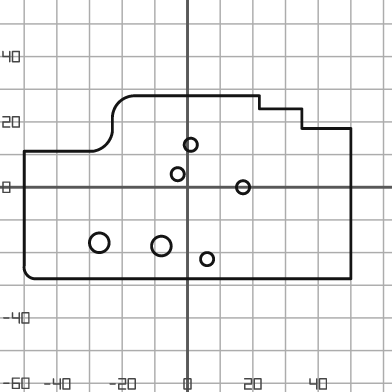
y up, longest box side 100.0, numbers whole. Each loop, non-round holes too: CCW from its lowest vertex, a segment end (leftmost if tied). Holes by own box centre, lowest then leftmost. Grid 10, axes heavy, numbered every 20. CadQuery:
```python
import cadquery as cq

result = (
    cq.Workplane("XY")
    .moveTo(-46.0, -28.0)
    .lineTo(50.0, -28.0)
    .lineTo(50.0, 18.0)
    .lineTo(35.0, 18.0)
    .lineTo(35.0, 24.0)
    .lineTo(22.0, 24.0)
    .lineTo(22.0, 28.0)
    .lineTo(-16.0, 28.0)
    .threePointArc((-21.0, 26.0), (-23.0, 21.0))
    .lineTo(-23.0, 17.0)
    .threePointArc((-25.0, 13.0), (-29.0, 11.0))
    .lineTo(-50.0, 11.0)
    .lineTo(-50.0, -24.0)
    .threePointArc((-49.0, -27.0), (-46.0, -28.0))
    .close()
    .moveTo(6.0, -22.0)
    .circle(2.0)
    .moveTo(-8.0, -18.0)
    .circle(3.0)
    .moveTo(-27.0, -17.0)
    .circle(3.0)
    .moveTo(17.0, 0.0)
    .circle(2.0)
    .moveTo(-3.0, 4.0)
    .circle(2.0)
    .moveTo(1.0, 13.0)
    .circle(2.0)
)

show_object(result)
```